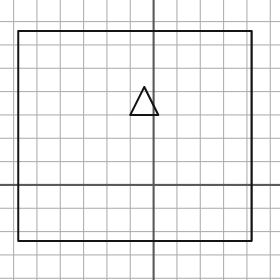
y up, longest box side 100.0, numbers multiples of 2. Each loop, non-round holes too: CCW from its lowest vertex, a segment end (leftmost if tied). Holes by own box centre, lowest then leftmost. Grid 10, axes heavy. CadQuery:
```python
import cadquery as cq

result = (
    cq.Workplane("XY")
    .moveTo(-58.0, -24.0)
    .lineTo(42.0, -24.0)
    .lineTo(42.0, 66.0)
    .lineTo(-58.0, 66.0)
    .close()
    .moveTo(-10.0, 30.0)
    .lineTo(2.0, 30.0)
    .lineTo(-4.0, 42.0)
    .close()
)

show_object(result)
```